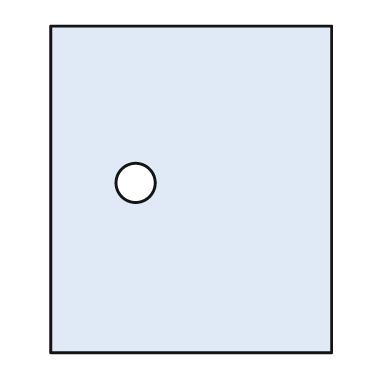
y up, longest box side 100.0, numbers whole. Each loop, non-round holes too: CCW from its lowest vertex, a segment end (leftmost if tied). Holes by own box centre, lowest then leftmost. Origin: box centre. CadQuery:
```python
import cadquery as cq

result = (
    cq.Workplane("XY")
    .moveTo(-43.0, -50.0)
    .lineTo(43.0, -50.0)
    .lineTo(43.0, 50.0)
    .lineTo(-43.0, 50.0)
    .close()
    .moveTo(-17.0, 2.0)
    .circle(6.0)
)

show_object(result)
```